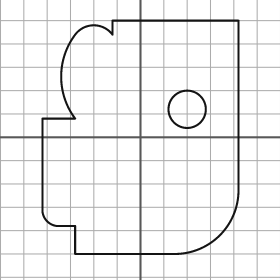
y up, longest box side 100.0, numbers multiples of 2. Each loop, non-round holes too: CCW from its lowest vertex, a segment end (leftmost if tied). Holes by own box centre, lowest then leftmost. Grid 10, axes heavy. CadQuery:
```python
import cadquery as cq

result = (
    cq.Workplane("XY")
    .moveTo(-28.0, -50.0)
    .lineTo(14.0, -50.0)
    .threePointArc((34.0, -42.0), (42.0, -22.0))
    .lineTo(42.0, 50.0)
    .lineTo(-12.0, 50.0)
    .lineTo(-12.0, 44.0)
    .threePointArc((-20.0, 48.0), (-28.0, 44.0))
    .threePointArc((-34.0, 26.0), (-28.0, 8.0))
    .lineTo(-42.0, 8.0)
    .lineTo(-42.0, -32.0)
    .threePointArc((-40.0, -36.0), (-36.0, -38.0))
    .lineTo(-28.0, -38.0)
    .close()
    .moveTo(20.0, 12.0)
    .circle(8.0)
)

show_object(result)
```